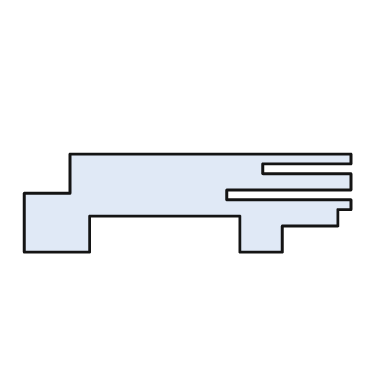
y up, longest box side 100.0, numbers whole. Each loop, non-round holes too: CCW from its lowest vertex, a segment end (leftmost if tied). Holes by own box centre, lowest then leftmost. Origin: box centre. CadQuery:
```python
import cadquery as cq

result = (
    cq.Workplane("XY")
    .moveTo(-50.0, -15.0)
    .lineTo(-30.0, -15.0)
    .lineTo(-30.0, -4.0)
    .lineTo(16.0, -4.0)
    .lineTo(16.0, -15.0)
    .lineTo(29.0, -15.0)
    .lineTo(29.0, -7.0)
    .lineTo(46.0, -7.0)
    .lineTo(46.0, -2.0)
    .lineTo(50.0, -2.0)
    .lineTo(50.0, 1.0)
    .lineTo(12.0, 1.0)
    .lineTo(12.0, 4.0)
    .lineTo(50.0, 4.0)
    .lineTo(50.0, 9.0)
    .lineTo(23.0, 9.0)
    .lineTo(23.0, 12.0)
    .lineTo(50.0, 12.0)
    .lineTo(50.0, 15.0)
    .lineTo(-36.0, 15.0)
    .lineTo(-36.0, 3.0)
    .lineTo(-50.0, 3.0)
    .close()
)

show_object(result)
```